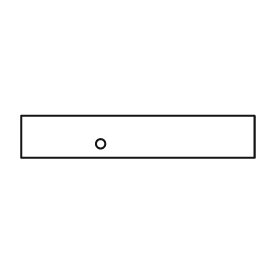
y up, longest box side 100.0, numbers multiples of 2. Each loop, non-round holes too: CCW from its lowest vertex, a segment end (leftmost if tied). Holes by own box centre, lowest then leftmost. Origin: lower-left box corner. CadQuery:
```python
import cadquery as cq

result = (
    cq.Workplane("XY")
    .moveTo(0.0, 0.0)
    .lineTo(100.0, 0.0)
    .lineTo(100.0, 18.0)
    .lineTo(0.0, 18.0)
    .close()
    .moveTo(34.0, 6.0)
    .circle(2.0)
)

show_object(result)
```